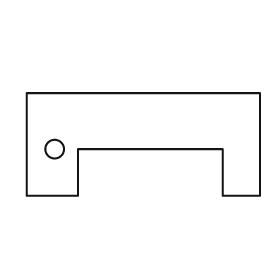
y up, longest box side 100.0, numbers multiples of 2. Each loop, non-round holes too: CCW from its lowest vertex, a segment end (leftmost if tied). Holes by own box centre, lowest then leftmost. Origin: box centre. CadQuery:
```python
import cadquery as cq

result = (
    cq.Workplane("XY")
    .moveTo(-50.0, -22.0)
    .lineTo(-28.0, -22.0)
    .lineTo(-28.0, -2.0)
    .lineTo(34.0, -2.0)
    .lineTo(34.0, -22.0)
    .lineTo(50.0, -22.0)
    .lineTo(50.0, 22.0)
    .lineTo(-50.0, 22.0)
    .close()
    .moveTo(-38.0, -2.0)
    .circle(4.0)
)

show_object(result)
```